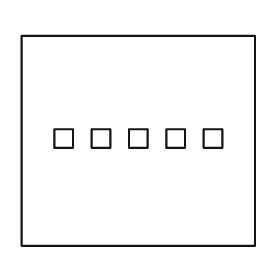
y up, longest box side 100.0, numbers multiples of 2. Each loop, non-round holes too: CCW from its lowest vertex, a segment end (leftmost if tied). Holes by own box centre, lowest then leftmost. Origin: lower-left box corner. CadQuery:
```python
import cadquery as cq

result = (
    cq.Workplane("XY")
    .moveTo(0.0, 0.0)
    .lineTo(100.0, 0.0)
    .lineTo(100.0, 90.0)
    .lineTo(0.0, 90.0)
    .close()
    .moveTo(14.0, 42.0)
    .lineTo(22.0, 42.0)
    .lineTo(22.0, 50.0)
    .lineTo(14.0, 50.0)
    .close()
    .moveTo(30.0, 42.0)
    .lineTo(38.0, 42.0)
    .lineTo(38.0, 50.0)
    .lineTo(30.0, 50.0)
    .close()
    .moveTo(46.0, 42.0)
    .lineTo(54.0, 42.0)
    .lineTo(54.0, 50.0)
    .lineTo(46.0, 50.0)
    .close()
    .moveTo(62.0, 42.0)
    .lineTo(70.0, 42.0)
    .lineTo(70.0, 50.0)
    .lineTo(62.0, 50.0)
    .close()
    .moveTo(78.0, 42.0)
    .lineTo(86.0, 42.0)
    .lineTo(86.0, 50.0)
    .lineTo(78.0, 50.0)
    .close()
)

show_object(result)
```